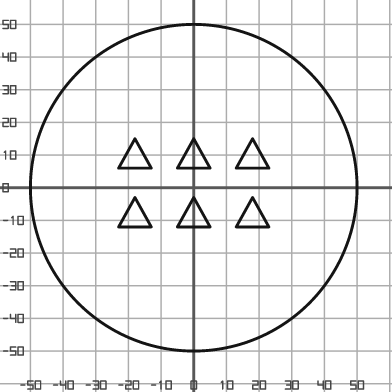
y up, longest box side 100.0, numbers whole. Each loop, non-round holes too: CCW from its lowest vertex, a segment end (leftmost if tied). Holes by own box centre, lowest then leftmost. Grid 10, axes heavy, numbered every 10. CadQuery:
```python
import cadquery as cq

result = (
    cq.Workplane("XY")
    .moveTo(0.0, 0.0)
    .circle(50.0)
    .moveTo(-23.0, -12.0)
    .lineTo(-13.0, -12.0)
    .lineTo(-18.0, -3.0)
    .close()
    .moveTo(-5.0, -12.0)
    .lineTo(5.0, -12.0)
    .lineTo(0.0, -3.0)
    .close()
    .moveTo(13.0, -12.0)
    .lineTo(23.0, -12.0)
    .lineTo(18.0, -3.0)
    .close()
    .moveTo(-23.0, 6.0)
    .lineTo(-13.0, 6.0)
    .lineTo(-18.0, 15.0)
    .close()
    .moveTo(-5.0, 6.0)
    .lineTo(5.0, 6.0)
    .lineTo(0.0, 15.0)
    .close()
    .moveTo(13.0, 6.0)
    .lineTo(23.0, 6.0)
    .lineTo(18.0, 15.0)
    .close()
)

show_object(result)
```